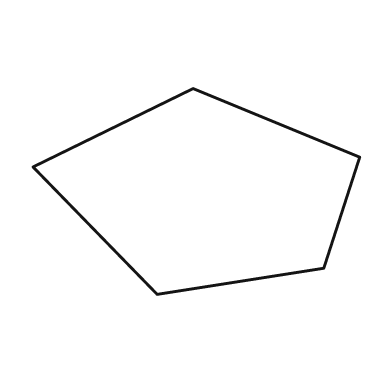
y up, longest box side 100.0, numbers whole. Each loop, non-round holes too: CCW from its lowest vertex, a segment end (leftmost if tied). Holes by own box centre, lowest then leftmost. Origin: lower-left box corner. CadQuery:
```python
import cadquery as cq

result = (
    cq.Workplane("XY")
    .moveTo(38.0, 0.0)
    .lineTo(89.0, 8.0)
    .lineTo(100.0, 42.0)
    .lineTo(49.0, 63.0)
    .lineTo(0.0, 39.0)
    .close()
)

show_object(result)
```